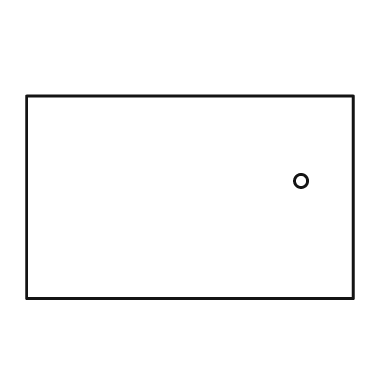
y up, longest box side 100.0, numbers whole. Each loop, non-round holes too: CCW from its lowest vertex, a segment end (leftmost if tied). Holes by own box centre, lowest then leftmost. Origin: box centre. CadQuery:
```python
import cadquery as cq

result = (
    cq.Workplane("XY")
    .moveTo(-50.0, -31.0)
    .lineTo(50.0, -31.0)
    .lineTo(50.0, 31.0)
    .lineTo(-50.0, 31.0)
    .close()
    .moveTo(34.0, 5.0)
    .circle(2.0)
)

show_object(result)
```